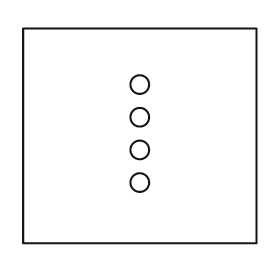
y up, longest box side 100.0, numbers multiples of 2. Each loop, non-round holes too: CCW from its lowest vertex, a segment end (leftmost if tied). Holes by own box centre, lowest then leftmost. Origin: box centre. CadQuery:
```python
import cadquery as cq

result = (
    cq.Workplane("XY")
    .moveTo(-50.0, -46.0)
    .lineTo(50.0, -46.0)
    .lineTo(50.0, 46.0)
    .lineTo(-50.0, 46.0)
    .close()
    .moveTo(0.0, -20.0)
    .circle(4.0)
    .moveTo(0.0, -6.0)
    .circle(4.0)
    .moveTo(0.0, 8.0)
    .circle(4.0)
    .moveTo(0.0, 22.0)
    .circle(4.0)
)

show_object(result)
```